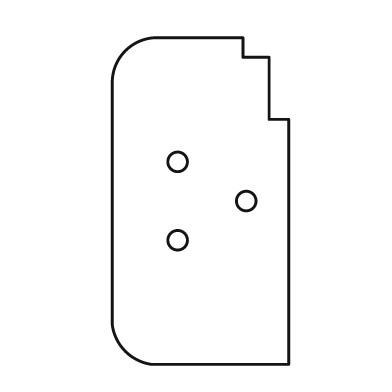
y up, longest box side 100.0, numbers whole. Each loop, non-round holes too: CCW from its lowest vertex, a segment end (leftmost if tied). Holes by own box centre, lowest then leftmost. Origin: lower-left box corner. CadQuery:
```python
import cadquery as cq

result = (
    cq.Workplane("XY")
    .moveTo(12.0, 0.0)
    .lineTo(54.0, 0.0)
    .lineTo(54.0, 75.0)
    .lineTo(48.0, 75.0)
    .lineTo(48.0, 94.0)
    .lineTo(40.0, 94.0)
    .lineTo(40.0, 100.0)
    .lineTo(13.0, 100.0)
    .threePointArc((4.0, 96.0), (0.0, 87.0))
    .lineTo(0.0, 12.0)
    .threePointArc((4.0, 4.0), (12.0, 0.0))
    .close()
    .moveTo(20.0, 38.0)
    .circle(3.0)
    .moveTo(41.0, 50.0)
    .circle(3.0)
    .moveTo(20.0, 62.0)
    .circle(3.0)
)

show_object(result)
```